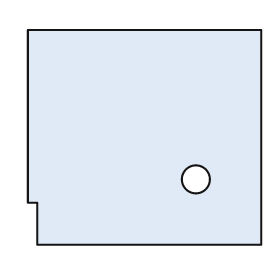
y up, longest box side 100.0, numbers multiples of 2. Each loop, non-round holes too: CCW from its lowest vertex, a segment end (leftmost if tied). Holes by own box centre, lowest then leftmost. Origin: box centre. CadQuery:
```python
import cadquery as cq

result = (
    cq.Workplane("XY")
    .moveTo(-46.0, -46.0)
    .lineTo(50.0, -46.0)
    .lineTo(50.0, 46.0)
    .lineTo(-50.0, 46.0)
    .lineTo(-50.0, -28.0)
    .lineTo(-46.0, -28.0)
    .close()
    .moveTo(22.0, -18.0)
    .circle(6.0)
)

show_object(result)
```